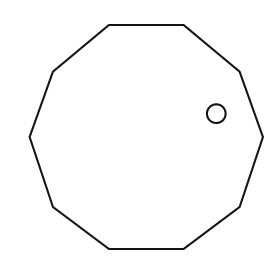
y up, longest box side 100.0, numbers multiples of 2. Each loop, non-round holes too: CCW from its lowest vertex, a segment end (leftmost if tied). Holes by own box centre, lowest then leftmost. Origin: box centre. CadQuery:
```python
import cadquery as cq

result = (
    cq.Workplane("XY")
    .moveTo(-16.0, -48.0)
    .lineTo(16.0, -48.0)
    .lineTo(40.0, -30.0)
    .lineTo(50.0, 0.0)
    .lineTo(40.0, 28.0)
    .lineTo(16.0, 48.0)
    .lineTo(-16.0, 48.0)
    .lineTo(-40.0, 28.0)
    .lineTo(-50.0, 0.0)
    .lineTo(-40.0, -30.0)
    .close()
    .moveTo(30.0, 10.0)
    .circle(4.0)
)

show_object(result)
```